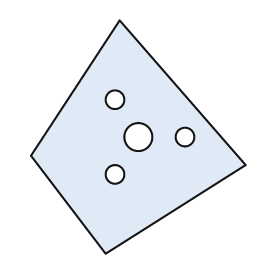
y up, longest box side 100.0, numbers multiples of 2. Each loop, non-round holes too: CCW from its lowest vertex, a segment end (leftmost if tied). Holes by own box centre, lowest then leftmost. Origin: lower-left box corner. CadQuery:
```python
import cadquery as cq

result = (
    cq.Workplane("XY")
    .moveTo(32.0, 0.0)
    .lineTo(92.0, 38.0)
    .lineTo(38.0, 100.0)
    .lineTo(0.0, 42.0)
    .close()
    .moveTo(36.0, 34.0)
    .circle(4.0)
    .moveTo(46.0, 50.0)
    .circle(6.0)
    .moveTo(66.0, 50.0)
    .circle(4.0)
    .moveTo(36.0, 66.0)
    .circle(4.0)
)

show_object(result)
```